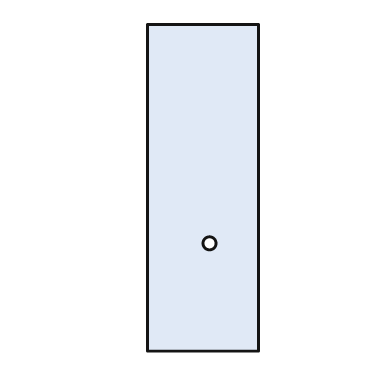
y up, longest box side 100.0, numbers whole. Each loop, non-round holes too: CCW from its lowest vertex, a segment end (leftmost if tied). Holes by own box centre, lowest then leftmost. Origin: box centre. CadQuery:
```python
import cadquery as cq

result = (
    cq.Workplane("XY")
    .moveTo(-17.0, -50.0)
    .lineTo(17.0, -50.0)
    .lineTo(17.0, 50.0)
    .lineTo(-17.0, 50.0)
    .close()
    .moveTo(2.0, -17.0)
    .circle(2.0)
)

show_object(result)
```